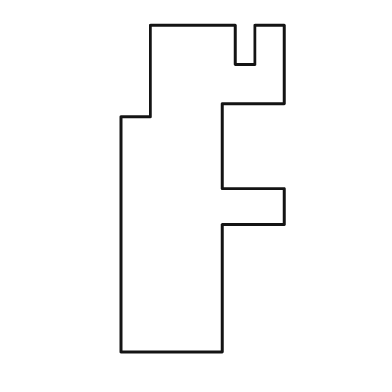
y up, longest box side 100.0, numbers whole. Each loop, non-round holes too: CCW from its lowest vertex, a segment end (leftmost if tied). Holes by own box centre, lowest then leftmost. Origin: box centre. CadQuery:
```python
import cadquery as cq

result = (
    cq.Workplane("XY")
    .moveTo(-25.0, -50.0)
    .lineTo(6.0, -50.0)
    .lineTo(6.0, -11.0)
    .lineTo(25.0, -11.0)
    .lineTo(25.0, 0.0)
    .lineTo(6.0, 0.0)
    .lineTo(6.0, 26.0)
    .lineTo(25.0, 26.0)
    .lineTo(25.0, 50.0)
    .lineTo(16.0, 50.0)
    .lineTo(16.0, 38.0)
    .lineTo(10.0, 38.0)
    .lineTo(10.0, 50.0)
    .lineTo(-16.0, 50.0)
    .lineTo(-16.0, 22.0)
    .lineTo(-25.0, 22.0)
    .close()
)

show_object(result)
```